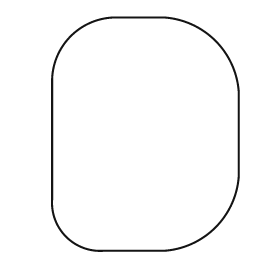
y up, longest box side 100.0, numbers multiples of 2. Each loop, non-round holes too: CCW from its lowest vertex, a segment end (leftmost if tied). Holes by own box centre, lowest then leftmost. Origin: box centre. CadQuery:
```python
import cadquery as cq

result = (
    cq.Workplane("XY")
    .moveTo(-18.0, -50.0)
    .lineTo(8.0, -50.0)
    .threePointArc((30.0, -40.0), (40.0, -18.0))
    .lineTo(40.0, 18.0)
    .threePointArc((30.0, 40.0), (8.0, 50.0))
    .lineTo(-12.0, 50.0)
    .threePointArc((-32.0, 42.0), (-40.0, 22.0))
    .lineTo(-40.0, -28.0)
    .threePointArc((-34.0, -44.0), (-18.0, -50.0))
    .close()
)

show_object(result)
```